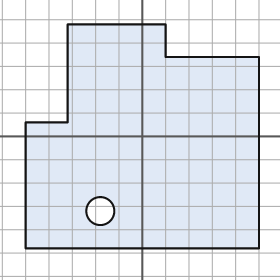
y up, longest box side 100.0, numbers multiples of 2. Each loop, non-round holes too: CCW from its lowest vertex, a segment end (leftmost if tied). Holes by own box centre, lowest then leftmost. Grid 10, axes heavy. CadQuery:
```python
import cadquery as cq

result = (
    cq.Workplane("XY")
    .moveTo(-50.0, -48.0)
    .lineTo(50.0, -48.0)
    .lineTo(50.0, 34.0)
    .lineTo(10.0, 34.0)
    .lineTo(10.0, 48.0)
    .lineTo(-32.0, 48.0)
    .lineTo(-32.0, 6.0)
    .lineTo(-50.0, 6.0)
    .close()
    .moveTo(-18.0, -32.0)
    .circle(6.0)
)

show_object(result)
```